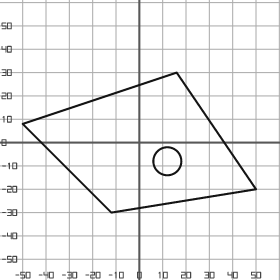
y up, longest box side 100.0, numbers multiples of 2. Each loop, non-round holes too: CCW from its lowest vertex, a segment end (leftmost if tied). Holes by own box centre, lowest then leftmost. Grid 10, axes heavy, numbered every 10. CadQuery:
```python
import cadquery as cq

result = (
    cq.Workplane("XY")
    .moveTo(-12.0, -30.0)
    .lineTo(50.0, -20.0)
    .lineTo(16.0, 30.0)
    .lineTo(-50.0, 8.0)
    .close()
    .moveTo(12.0, -8.0)
    .circle(6.0)
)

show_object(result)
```